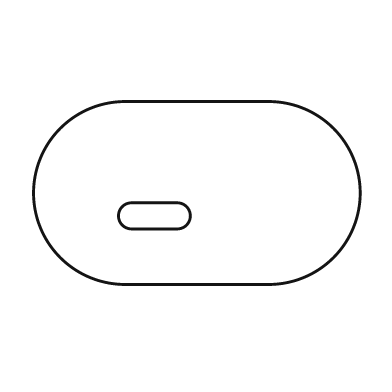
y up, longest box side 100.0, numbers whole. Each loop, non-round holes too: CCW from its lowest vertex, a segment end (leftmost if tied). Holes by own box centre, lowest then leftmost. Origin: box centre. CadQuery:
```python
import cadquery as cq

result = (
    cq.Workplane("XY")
    .moveTo(-22.0, -28.0)
    .lineTo(22.0, -28.0)
    .threePointArc((50.0, 0.0), (22.0, 28.0))
    .lineTo(-22.0, 28.0)
    .threePointArc((-50.0, 0.0), (-22.0, -28.0))
    .close()
    .moveTo(-20.0, -11.0)
    .lineTo(-6.0, -11.0)
    .threePointArc((-2.0, -7.0), (-6.0, -3.0))
    .lineTo(-20.0, -3.0)
    .threePointArc((-24.0, -7.0), (-20.0, -11.0))
    .close()
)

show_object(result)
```